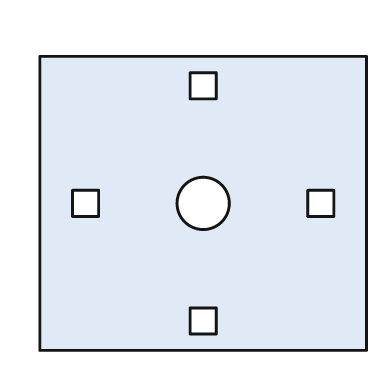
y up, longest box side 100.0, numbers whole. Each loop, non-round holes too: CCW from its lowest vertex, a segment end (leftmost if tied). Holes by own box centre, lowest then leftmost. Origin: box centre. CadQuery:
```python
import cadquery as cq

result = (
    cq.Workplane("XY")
    .moveTo(-50.0, -45.0)
    .lineTo(50.0, -45.0)
    .lineTo(50.0, 45.0)
    .lineTo(-50.0, 45.0)
    .close()
    .moveTo(-4.0, -40.0)
    .lineTo(4.0, -40.0)
    .lineTo(4.0, -32.0)
    .lineTo(-4.0, -32.0)
    .close()
    .moveTo(-40.0, -4.0)
    .lineTo(-32.0, -4.0)
    .lineTo(-32.0, 4.0)
    .lineTo(-40.0, 4.0)
    .close()
    .moveTo(0.0, 0.0)
    .circle(8.0)
    .moveTo(32.0, -4.0)
    .lineTo(40.0, -4.0)
    .lineTo(40.0, 4.0)
    .lineTo(32.0, 4.0)
    .close()
    .moveTo(-4.0, 32.0)
    .lineTo(4.0, 32.0)
    .lineTo(4.0, 40.0)
    .lineTo(-4.0, 40.0)
    .close()
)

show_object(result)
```